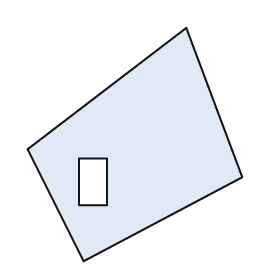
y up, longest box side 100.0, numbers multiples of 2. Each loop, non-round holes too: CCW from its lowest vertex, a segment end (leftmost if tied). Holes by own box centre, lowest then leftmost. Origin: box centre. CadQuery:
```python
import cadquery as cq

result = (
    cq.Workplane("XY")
    .moveTo(-22.0, -50.0)
    .lineTo(46.0, -14.0)
    .lineTo(22.0, 50.0)
    .lineTo(-46.0, -2.0)
    .close()
    .moveTo(-24.0, -26.0)
    .lineTo(-12.0, -26.0)
    .lineTo(-12.0, -6.0)
    .lineTo(-24.0, -6.0)
    .close()
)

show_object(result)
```